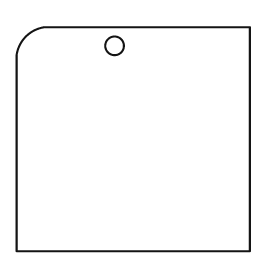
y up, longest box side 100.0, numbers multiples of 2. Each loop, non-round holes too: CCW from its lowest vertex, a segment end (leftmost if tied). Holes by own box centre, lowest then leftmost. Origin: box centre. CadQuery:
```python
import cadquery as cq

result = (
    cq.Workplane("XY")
    .moveTo(-50.0, -48.0)
    .lineTo(50.0, -48.0)
    .lineTo(50.0, 48.0)
    .lineTo(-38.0, 48.0)
    .threePointArc((-46.0, 44.0), (-50.0, 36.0))
    .close()
    .moveTo(-8.0, 40.0)
    .circle(4.0)
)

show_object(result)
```